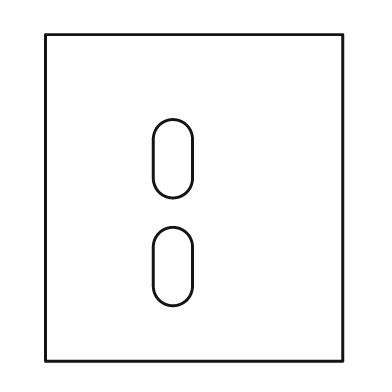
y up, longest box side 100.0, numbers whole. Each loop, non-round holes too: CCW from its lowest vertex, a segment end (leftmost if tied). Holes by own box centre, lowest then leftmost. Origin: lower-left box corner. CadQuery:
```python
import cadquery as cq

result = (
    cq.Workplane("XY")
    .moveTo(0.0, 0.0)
    .lineTo(91.0, 0.0)
    .lineTo(91.0, 100.0)
    .lineTo(0.0, 100.0)
    .close()
    .moveTo(33.0, 23.0)
    .threePointArc((39.0, 17.0), (45.0, 23.0))
    .lineTo(45.0, 35.0)
    .threePointArc((39.0, 41.0), (33.0, 35.0))
    .close()
    .moveTo(33.0, 56.0)
    .threePointArc((39.0, 50.0), (45.0, 56.0))
    .lineTo(45.0, 68.0)
    .threePointArc((39.0, 74.0), (33.0, 68.0))
    .close()
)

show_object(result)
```